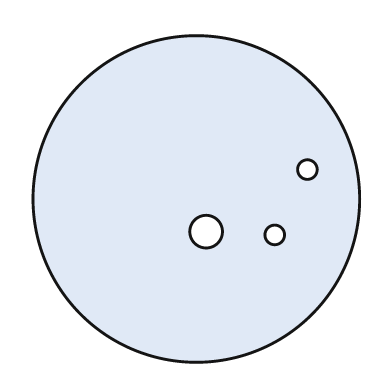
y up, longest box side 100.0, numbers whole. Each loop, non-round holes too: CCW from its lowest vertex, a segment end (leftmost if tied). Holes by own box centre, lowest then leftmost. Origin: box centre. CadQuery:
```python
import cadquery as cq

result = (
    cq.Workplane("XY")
    .moveTo(0.0, 0.0)
    .circle(50.0)
    .moveTo(24.0, -11.0)
    .circle(3.0)
    .moveTo(3.0, -10.0)
    .circle(5.0)
    .moveTo(34.0, 9.0)
    .circle(3.0)
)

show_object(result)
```